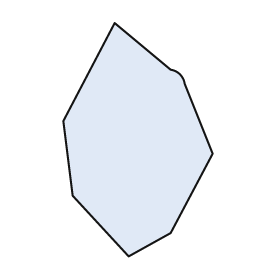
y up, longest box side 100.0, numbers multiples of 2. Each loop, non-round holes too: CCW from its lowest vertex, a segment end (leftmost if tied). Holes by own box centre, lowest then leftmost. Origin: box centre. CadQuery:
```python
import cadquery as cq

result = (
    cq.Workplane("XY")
    .moveTo(-4.0, -50.0)
    .lineTo(14.0, -40.0)
    .lineTo(32.0, -6.0)
    .lineTo(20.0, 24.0)
    .threePointArc((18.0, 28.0), (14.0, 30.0))
    .lineTo(-10.0, 50.0)
    .lineTo(-32.0, 8.0)
    .lineTo(-28.0, -24.0)
    .close()
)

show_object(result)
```